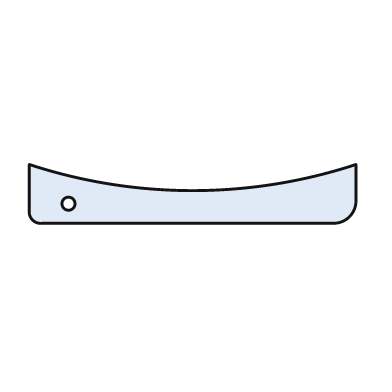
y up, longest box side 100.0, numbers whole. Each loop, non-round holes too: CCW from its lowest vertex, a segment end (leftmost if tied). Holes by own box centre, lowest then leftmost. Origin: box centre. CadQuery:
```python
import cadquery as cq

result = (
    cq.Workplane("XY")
    .moveTo(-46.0, -9.0)
    .lineTo(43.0, -9.0)
    .threePointArc((48.0, -7.0), (50.0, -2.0))
    .lineTo(50.0, 9.0)
    .threePointArc((0.0, 1.0), (-50.0, 9.0))
    .lineTo(-50.0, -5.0)
    .threePointArc((-49.0, -8.0), (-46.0, -9.0))
    .close()
    .moveTo(-38.0, -3.0)
    .circle(2.0)
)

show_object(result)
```